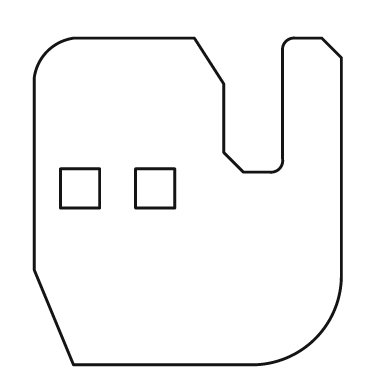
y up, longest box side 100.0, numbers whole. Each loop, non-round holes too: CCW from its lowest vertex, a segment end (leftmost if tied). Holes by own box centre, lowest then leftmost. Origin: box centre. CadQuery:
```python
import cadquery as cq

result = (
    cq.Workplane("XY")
    .moveTo(-35.0, -50.0)
    .lineTo(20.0, -50.0)
    .threePointArc((39.0, -42.0), (47.0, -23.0))
    .lineTo(47.0, 44.0)
    .lineTo(41.0, 50.0)
    .lineTo(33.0, 50.0)
    .threePointArc((30.0, 49.0), (29.0, 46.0))
    .lineTo(29.0, 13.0)
    .threePointArc((28.0, 10.0), (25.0, 9.0))
    .lineTo(17.0, 9.0)
    .lineTo(11.0, 15.0)
    .lineTo(11.0, 36.0)
    .lineTo(2.0, 50.0)
    .lineTo(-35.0, 50.0)
    .threePointArc((-43.0, 46.0), (-47.0, 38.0))
    .lineTo(-47.0, -21.0)
    .close()
    .moveTo(-39.0, -2.0)
    .lineTo(-27.0, -2.0)
    .lineTo(-27.0, 10.0)
    .lineTo(-39.0, 10.0)
    .close()
    .moveTo(-16.0, -2.0)
    .lineTo(-4.0, -2.0)
    .lineTo(-4.0, 10.0)
    .lineTo(-16.0, 10.0)
    .close()
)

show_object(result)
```